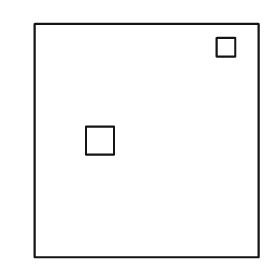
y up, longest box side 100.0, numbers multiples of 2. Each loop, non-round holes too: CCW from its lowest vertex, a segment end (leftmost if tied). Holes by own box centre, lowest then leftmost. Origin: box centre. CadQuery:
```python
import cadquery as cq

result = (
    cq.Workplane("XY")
    .moveTo(-48.0, -50.0)
    .lineTo(48.0, -50.0)
    .lineTo(48.0, 50.0)
    .lineTo(-48.0, 50.0)
    .close()
    .moveTo(-26.0, -6.0)
    .lineTo(-14.0, -6.0)
    .lineTo(-14.0, 6.0)
    .lineTo(-26.0, 6.0)
    .close()
    .moveTo(30.0, 36.0)
    .lineTo(38.0, 36.0)
    .lineTo(38.0, 44.0)
    .lineTo(30.0, 44.0)
    .close()
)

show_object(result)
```